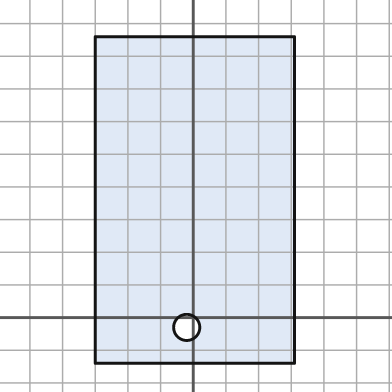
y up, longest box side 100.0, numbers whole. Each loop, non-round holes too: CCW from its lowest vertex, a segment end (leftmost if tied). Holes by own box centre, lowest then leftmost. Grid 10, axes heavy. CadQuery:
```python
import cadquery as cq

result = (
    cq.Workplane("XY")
    .moveTo(-30.0, -14.0)
    .lineTo(31.0, -14.0)
    .lineTo(31.0, 86.0)
    .lineTo(-30.0, 86.0)
    .close()
    .moveTo(-2.0, -3.0)
    .circle(4.0)
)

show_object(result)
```